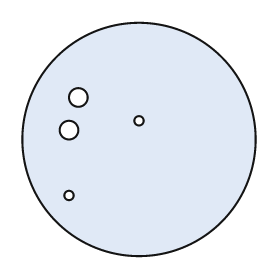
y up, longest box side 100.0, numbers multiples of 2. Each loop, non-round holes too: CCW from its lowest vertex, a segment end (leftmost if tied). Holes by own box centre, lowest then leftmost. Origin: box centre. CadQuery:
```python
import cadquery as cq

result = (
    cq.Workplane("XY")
    .moveTo(0.0, 0.0)
    .circle(50.0)
    .moveTo(-30.0, -24.0)
    .circle(2.0)
    .moveTo(-30.0, 4.0)
    .circle(4.0)
    .moveTo(0.0, 8.0)
    .circle(2.0)
    .moveTo(-26.0, 18.0)
    .circle(4.0)
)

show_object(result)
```